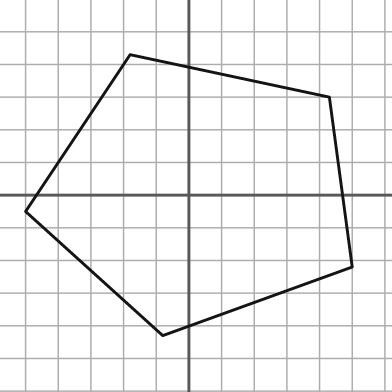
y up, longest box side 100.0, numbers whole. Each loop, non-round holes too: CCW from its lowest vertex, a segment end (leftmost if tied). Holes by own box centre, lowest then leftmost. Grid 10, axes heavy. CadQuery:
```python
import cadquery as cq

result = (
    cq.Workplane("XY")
    .moveTo(-8.0, -43.0)
    .lineTo(50.0, -22.0)
    .lineTo(43.0, 30.0)
    .lineTo(-18.0, 43.0)
    .lineTo(-50.0, -5.0)
    .close()
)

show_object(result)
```